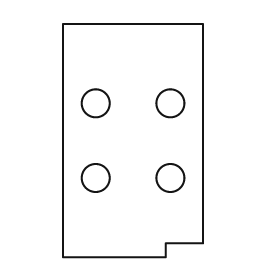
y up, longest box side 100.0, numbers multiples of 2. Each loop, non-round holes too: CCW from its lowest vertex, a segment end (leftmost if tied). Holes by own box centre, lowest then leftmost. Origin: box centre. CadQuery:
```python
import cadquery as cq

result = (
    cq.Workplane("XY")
    .moveTo(-30.0, -50.0)
    .lineTo(14.0, -50.0)
    .lineTo(14.0, -44.0)
    .lineTo(30.0, -44.0)
    .lineTo(30.0, 50.0)
    .lineTo(-30.0, 50.0)
    .close()
    .moveTo(-16.0, -16.0)
    .circle(6.0)
    .moveTo(16.0, -16.0)
    .circle(6.0)
    .moveTo(-16.0, 16.0)
    .circle(6.0)
    .moveTo(16.0, 16.0)
    .circle(6.0)
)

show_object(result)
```